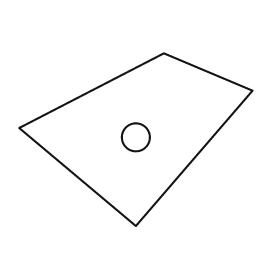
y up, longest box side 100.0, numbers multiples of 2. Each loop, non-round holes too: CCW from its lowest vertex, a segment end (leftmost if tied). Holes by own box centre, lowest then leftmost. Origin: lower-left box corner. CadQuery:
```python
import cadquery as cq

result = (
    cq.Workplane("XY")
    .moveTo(50.0, 0.0)
    .lineTo(100.0, 58.0)
    .lineTo(62.0, 74.0)
    .lineTo(0.0, 42.0)
    .close()
    .moveTo(50.0, 38.0)
    .circle(6.0)
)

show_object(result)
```